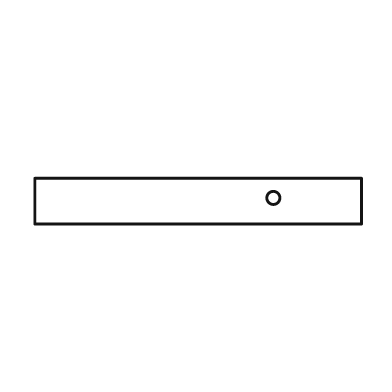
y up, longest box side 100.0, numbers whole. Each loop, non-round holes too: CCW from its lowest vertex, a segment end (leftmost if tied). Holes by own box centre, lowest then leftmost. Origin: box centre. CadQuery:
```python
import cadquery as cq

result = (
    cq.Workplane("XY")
    .moveTo(-50.0, -7.0)
    .lineTo(50.0, -7.0)
    .lineTo(50.0, 7.0)
    .lineTo(-50.0, 7.0)
    .close()
    .moveTo(23.0, 1.0)
    .circle(2.0)
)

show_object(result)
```